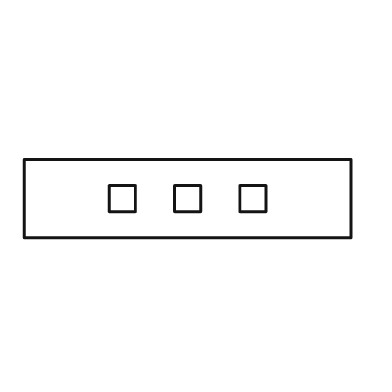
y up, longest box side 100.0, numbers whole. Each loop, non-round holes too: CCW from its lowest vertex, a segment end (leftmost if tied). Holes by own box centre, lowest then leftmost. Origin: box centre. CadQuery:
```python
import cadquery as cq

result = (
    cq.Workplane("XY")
    .moveTo(-50.0, -12.0)
    .lineTo(50.0, -12.0)
    .lineTo(50.0, 12.0)
    .lineTo(-50.0, 12.0)
    .close()
    .moveTo(-24.0, -4.0)
    .lineTo(-16.0, -4.0)
    .lineTo(-16.0, 4.0)
    .lineTo(-24.0, 4.0)
    .close()
    .moveTo(-4.0, -4.0)
    .lineTo(4.0, -4.0)
    .lineTo(4.0, 4.0)
    .lineTo(-4.0, 4.0)
    .close()
    .moveTo(16.0, -4.0)
    .lineTo(24.0, -4.0)
    .lineTo(24.0, 4.0)
    .lineTo(16.0, 4.0)
    .close()
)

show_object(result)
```